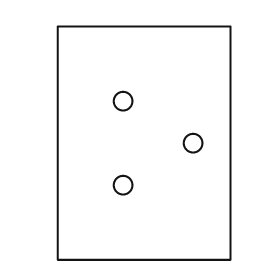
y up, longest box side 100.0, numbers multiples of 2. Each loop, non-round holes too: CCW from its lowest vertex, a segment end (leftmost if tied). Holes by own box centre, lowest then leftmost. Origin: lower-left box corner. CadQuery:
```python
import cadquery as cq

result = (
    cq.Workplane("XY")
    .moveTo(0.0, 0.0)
    .lineTo(74.0, 0.0)
    .lineTo(74.0, 100.0)
    .lineTo(0.0, 100.0)
    .close()
    .moveTo(28.0, 32.0)
    .circle(4.0)
    .moveTo(58.0, 50.0)
    .circle(4.0)
    .moveTo(28.0, 68.0)
    .circle(4.0)
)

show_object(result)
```